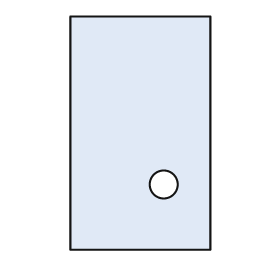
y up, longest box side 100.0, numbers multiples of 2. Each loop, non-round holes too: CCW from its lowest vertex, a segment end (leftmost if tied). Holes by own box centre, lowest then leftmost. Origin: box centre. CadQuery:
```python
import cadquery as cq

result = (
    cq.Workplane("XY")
    .moveTo(-30.0, -50.0)
    .lineTo(30.0, -50.0)
    .lineTo(30.0, 50.0)
    .lineTo(-30.0, 50.0)
    .close()
    .moveTo(10.0, -22.0)
    .circle(6.0)
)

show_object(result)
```